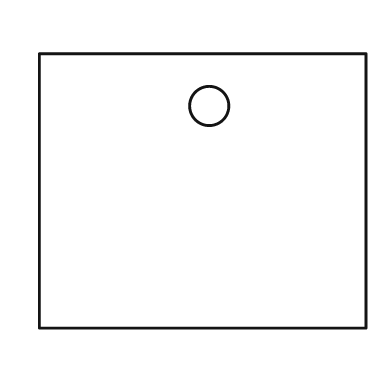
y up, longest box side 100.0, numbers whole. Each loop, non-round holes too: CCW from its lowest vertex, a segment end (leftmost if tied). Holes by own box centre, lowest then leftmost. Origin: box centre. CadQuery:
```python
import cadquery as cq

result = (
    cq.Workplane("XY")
    .moveTo(-50.0, -42.0)
    .lineTo(50.0, -42.0)
    .lineTo(50.0, 42.0)
    .lineTo(-50.0, 42.0)
    .close()
    .moveTo(2.0, 26.0)
    .circle(6.0)
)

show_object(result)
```